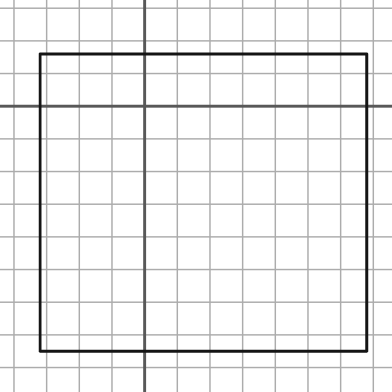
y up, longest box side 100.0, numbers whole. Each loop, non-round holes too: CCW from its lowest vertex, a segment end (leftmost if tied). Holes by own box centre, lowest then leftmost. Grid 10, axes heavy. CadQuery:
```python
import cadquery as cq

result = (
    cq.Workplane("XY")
    .moveTo(-32.0, -75.0)
    .lineTo(68.0, -75.0)
    .lineTo(68.0, 16.0)
    .lineTo(-32.0, 16.0)
    .close()
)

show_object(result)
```